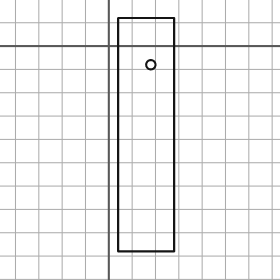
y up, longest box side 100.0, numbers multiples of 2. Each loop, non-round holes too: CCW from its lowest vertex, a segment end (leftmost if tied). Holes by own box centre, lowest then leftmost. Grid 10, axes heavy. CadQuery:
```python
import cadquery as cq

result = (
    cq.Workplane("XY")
    .moveTo(4.0, -88.0)
    .lineTo(28.0, -88.0)
    .lineTo(28.0, 12.0)
    .lineTo(4.0, 12.0)
    .close()
    .moveTo(18.0, -8.0)
    .circle(2.0)
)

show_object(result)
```